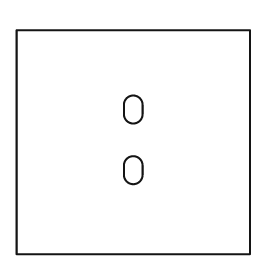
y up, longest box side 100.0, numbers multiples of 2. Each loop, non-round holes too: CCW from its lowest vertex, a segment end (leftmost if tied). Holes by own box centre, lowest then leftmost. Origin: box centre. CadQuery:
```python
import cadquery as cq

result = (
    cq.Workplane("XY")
    .moveTo(-50.0, -48.0)
    .lineTo(50.0, -48.0)
    .lineTo(50.0, 48.0)
    .lineTo(-50.0, 48.0)
    .close()
    .moveTo(-4.0, -14.0)
    .threePointArc((0.0, -18.0), (4.0, -14.0))
    .lineTo(4.0, -10.0)
    .threePointArc((0.0, -6.0), (-4.0, -10.0))
    .close()
    .moveTo(-4.0, 12.0)
    .threePointArc((0.0, 8.0), (4.0, 12.0))
    .lineTo(4.0, 16.0)
    .threePointArc((0.0, 20.0), (-4.0, 16.0))
    .close()
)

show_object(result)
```